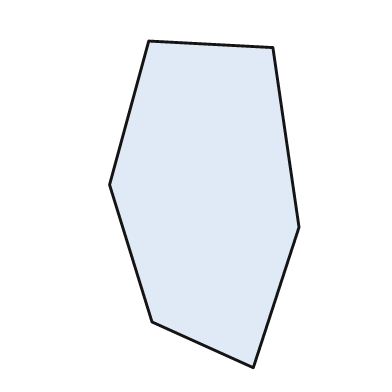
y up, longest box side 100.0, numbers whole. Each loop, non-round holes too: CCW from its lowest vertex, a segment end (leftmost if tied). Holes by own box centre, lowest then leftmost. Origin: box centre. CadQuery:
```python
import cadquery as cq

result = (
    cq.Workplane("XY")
    .moveTo(15.0, -50.0)
    .lineTo(29.0, -7.0)
    .lineTo(21.0, 48.0)
    .lineTo(-17.0, 50.0)
    .lineTo(-29.0, 6.0)
    .lineTo(-16.0, -36.0)
    .close()
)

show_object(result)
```